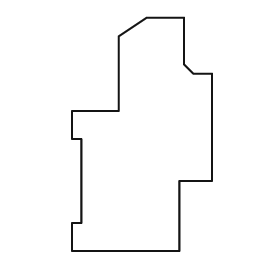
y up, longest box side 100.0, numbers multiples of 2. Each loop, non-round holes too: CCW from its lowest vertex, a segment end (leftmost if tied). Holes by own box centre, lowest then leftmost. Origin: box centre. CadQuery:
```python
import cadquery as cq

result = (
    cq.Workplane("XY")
    .moveTo(-30.0, -50.0)
    .lineTo(16.0, -50.0)
    .lineTo(16.0, -20.0)
    .lineTo(30.0, -20.0)
    .lineTo(30.0, 26.0)
    .lineTo(22.0, 26.0)
    .lineTo(18.0, 30.0)
    .lineTo(18.0, 50.0)
    .lineTo(2.0, 50.0)
    .lineTo(-10.0, 42.0)
    .lineTo(-10.0, 10.0)
    .lineTo(-30.0, 10.0)
    .lineTo(-30.0, -2.0)
    .lineTo(-26.0, -2.0)
    .lineTo(-26.0, -38.0)
    .lineTo(-30.0, -38.0)
    .close()
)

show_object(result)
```